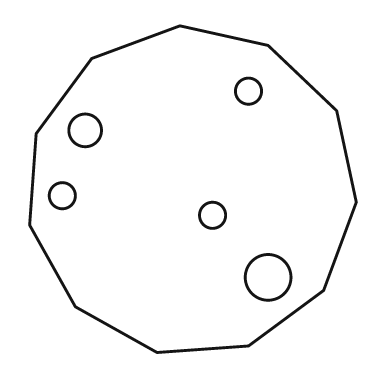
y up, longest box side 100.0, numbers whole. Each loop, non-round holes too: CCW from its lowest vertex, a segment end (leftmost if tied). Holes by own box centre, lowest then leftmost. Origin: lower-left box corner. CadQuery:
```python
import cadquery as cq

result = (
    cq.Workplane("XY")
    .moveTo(39.0, 0.0)
    .lineTo(67.0, 2.0)
    .lineTo(90.0, 19.0)
    .lineTo(100.0, 46.0)
    .lineTo(94.0, 74.0)
    .lineTo(73.0, 94.0)
    .lineTo(46.0, 100.0)
    .lineTo(19.0, 90.0)
    .lineTo(2.0, 67.0)
    .lineTo(0.0, 39.0)
    .lineTo(14.0, 14.0)
    .close()
    .moveTo(73.0, 23.0)
    .circle(7.0)
    .moveTo(56.0, 42.0)
    .circle(4.0)
    .moveTo(10.0, 48.0)
    .circle(4.0)
    .moveTo(17.0, 68.0)
    .circle(5.0)
    .moveTo(67.0, 80.0)
    .circle(4.0)
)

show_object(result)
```